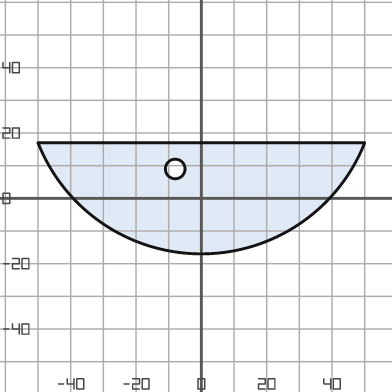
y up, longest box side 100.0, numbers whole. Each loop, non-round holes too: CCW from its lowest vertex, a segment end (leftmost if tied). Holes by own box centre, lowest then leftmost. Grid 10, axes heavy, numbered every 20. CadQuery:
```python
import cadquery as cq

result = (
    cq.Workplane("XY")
    .moveTo(-50.0, 17.0)
    .threePointArc((0.0, -17.0), (50.0, 17.0))
    .close()
    .moveTo(-8.0, 9.0)
    .circle(3.0)
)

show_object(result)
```